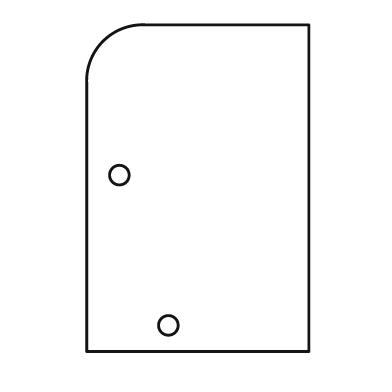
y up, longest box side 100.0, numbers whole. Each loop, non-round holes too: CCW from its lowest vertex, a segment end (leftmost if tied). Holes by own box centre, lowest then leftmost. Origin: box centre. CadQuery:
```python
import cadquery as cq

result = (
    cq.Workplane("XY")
    .moveTo(-34.0, -50.0)
    .lineTo(34.0, -50.0)
    .lineTo(34.0, 50.0)
    .lineTo(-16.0, 50.0)
    .threePointArc((-29.0, 45.0), (-34.0, 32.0))
    .close()
    .moveTo(-9.0, -42.0)
    .circle(3.0)
    .moveTo(-24.0, 4.0)
    .circle(3.0)
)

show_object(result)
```